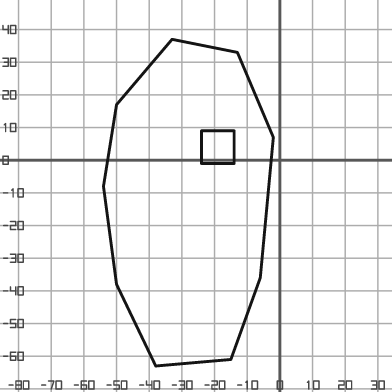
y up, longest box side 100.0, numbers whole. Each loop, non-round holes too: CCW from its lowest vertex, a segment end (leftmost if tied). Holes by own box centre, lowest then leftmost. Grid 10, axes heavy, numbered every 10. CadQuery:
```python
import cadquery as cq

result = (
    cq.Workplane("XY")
    .moveTo(-38.0, -63.0)
    .lineTo(-15.0, -61.0)
    .lineTo(-6.0, -36.0)
    .lineTo(-2.0, 7.0)
    .lineTo(-13.0, 33.0)
    .lineTo(-33.0, 37.0)
    .lineTo(-50.0, 17.0)
    .lineTo(-54.0, -8.0)
    .lineTo(-50.0, -38.0)
    .close()
    .moveTo(-24.0, -1.0)
    .lineTo(-14.0, -1.0)
    .lineTo(-14.0, 9.0)
    .lineTo(-24.0, 9.0)
    .close()
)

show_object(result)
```